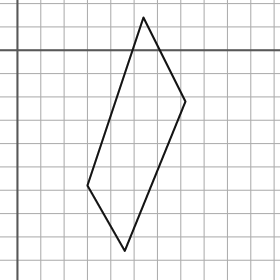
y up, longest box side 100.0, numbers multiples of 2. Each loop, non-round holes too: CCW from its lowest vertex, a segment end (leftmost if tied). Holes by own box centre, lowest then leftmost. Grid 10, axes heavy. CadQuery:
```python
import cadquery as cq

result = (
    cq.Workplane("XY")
    .moveTo(46.0, -86.0)
    .lineTo(72.0, -22.0)
    .lineTo(54.0, 14.0)
    .lineTo(30.0, -58.0)
    .close()
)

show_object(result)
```